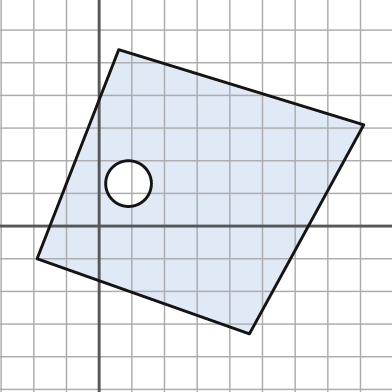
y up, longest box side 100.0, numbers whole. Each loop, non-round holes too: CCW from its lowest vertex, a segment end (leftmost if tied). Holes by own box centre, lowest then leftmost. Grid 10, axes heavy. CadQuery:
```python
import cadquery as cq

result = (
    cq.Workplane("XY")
    .moveTo(46.0, -33.0)
    .lineTo(81.0, 31.0)
    .lineTo(6.0, 54.0)
    .lineTo(-19.0, -10.0)
    .close()
    .moveTo(9.0, 13.0)
    .circle(7.0)
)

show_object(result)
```